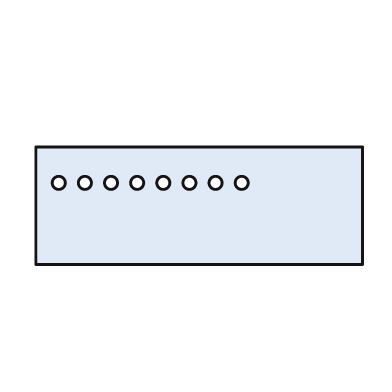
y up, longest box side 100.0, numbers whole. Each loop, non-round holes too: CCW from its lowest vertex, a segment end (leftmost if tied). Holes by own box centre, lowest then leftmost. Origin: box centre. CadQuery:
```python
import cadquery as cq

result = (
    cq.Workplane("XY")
    .moveTo(-50.0, -18.0)
    .lineTo(50.0, -18.0)
    .lineTo(50.0, 18.0)
    .lineTo(-50.0, 18.0)
    .close()
    .moveTo(-43.0, 7.0)
    .circle(2.0)
    .moveTo(-35.0, 7.0)
    .circle(2.0)
    .moveTo(-27.0, 7.0)
    .circle(2.0)
    .moveTo(-19.0, 7.0)
    .circle(2.0)
    .moveTo(-11.0, 7.0)
    .circle(2.0)
    .moveTo(-3.0, 7.0)
    .circle(2.0)
    .moveTo(5.0, 7.0)
    .circle(2.0)
    .moveTo(13.0, 7.0)
    .circle(2.0)
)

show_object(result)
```